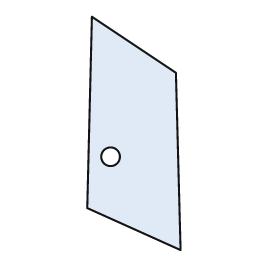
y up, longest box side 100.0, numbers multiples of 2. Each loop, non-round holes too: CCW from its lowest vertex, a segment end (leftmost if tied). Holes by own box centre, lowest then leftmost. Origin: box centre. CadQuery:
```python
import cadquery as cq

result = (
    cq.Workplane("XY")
    .moveTo(20.0, -50.0)
    .lineTo(18.0, 26.0)
    .lineTo(-18.0, 50.0)
    .lineTo(-20.0, -32.0)
    .close()
    .moveTo(-10.0, -10.0)
    .circle(4.0)
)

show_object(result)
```